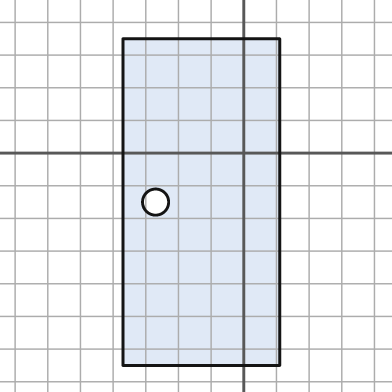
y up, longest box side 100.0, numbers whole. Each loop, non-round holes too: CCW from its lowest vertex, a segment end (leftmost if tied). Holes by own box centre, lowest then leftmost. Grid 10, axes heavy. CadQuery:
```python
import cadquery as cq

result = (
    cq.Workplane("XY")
    .moveTo(-37.0, -65.0)
    .lineTo(11.0, -65.0)
    .lineTo(11.0, 35.0)
    .lineTo(-37.0, 35.0)
    .close()
    .moveTo(-27.0, -15.0)
    .circle(4.0)
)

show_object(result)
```